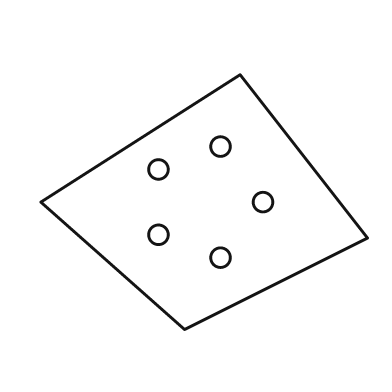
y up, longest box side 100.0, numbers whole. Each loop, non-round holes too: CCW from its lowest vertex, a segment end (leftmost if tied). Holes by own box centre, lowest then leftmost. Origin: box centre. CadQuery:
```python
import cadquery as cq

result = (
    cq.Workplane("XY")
    .moveTo(-6.0, -39.0)
    .lineTo(50.0, -11.0)
    .lineTo(11.0, 39.0)
    .lineTo(-50.0, 0.0)
    .close()
    .moveTo(5.0, -17.0)
    .circle(3.0)
    .moveTo(-14.0, -10.0)
    .circle(3.0)
    .moveTo(18.0, 0.0)
    .circle(3.0)
    .moveTo(-14.0, 10.0)
    .circle(3.0)
    .moveTo(5.0, 17.0)
    .circle(3.0)
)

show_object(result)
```